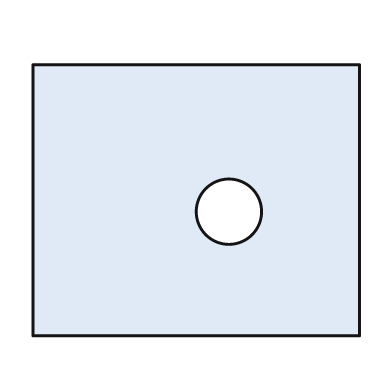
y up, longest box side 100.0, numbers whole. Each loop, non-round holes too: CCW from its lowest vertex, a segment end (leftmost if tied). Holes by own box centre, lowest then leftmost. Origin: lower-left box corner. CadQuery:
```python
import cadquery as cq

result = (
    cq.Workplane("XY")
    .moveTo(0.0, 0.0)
    .lineTo(100.0, 0.0)
    .lineTo(100.0, 83.0)
    .lineTo(0.0, 83.0)
    .close()
    .moveTo(60.0, 38.0)
    .circle(10.0)
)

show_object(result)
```